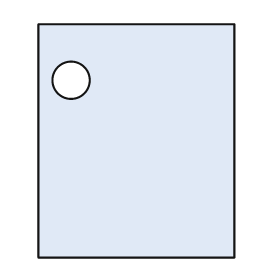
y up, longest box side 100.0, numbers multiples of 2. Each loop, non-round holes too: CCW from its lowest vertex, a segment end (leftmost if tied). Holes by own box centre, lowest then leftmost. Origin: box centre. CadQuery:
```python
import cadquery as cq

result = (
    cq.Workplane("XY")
    .moveTo(-42.0, -50.0)
    .lineTo(42.0, -50.0)
    .lineTo(42.0, 50.0)
    .lineTo(-42.0, 50.0)
    .close()
    .moveTo(-28.0, 26.0)
    .circle(8.0)
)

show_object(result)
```